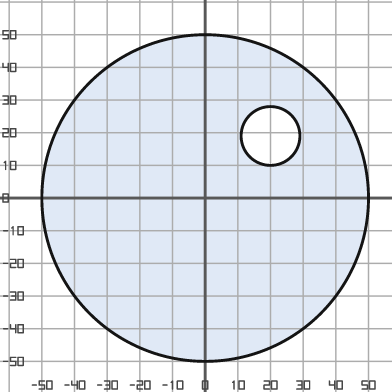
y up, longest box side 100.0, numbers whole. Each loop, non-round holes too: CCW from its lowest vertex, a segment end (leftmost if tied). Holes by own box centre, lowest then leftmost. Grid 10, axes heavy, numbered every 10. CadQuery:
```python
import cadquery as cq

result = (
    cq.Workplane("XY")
    .moveTo(0.0, 0.0)
    .circle(50.0)
    .moveTo(20.0, 19.0)
    .circle(9.0)
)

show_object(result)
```